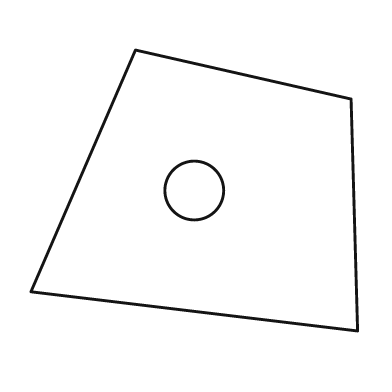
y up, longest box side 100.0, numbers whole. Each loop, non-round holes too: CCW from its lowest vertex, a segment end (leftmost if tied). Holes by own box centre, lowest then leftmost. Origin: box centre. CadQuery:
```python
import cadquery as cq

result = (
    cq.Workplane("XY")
    .moveTo(50.0, -43.0)
    .lineTo(48.0, 28.0)
    .lineTo(-18.0, 43.0)
    .lineTo(-50.0, -31.0)
    .close()
    .moveTo(0.0, 0.0)
    .circle(9.0)
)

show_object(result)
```